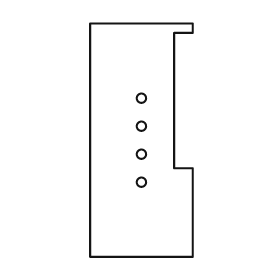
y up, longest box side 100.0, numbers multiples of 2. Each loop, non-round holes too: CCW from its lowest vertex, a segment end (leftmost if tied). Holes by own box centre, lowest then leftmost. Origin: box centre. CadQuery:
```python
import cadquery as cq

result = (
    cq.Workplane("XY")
    .moveTo(-22.0, -50.0)
    .lineTo(22.0, -50.0)
    .lineTo(22.0, -12.0)
    .lineTo(14.0, -12.0)
    .lineTo(14.0, 46.0)
    .lineTo(22.0, 46.0)
    .lineTo(22.0, 50.0)
    .lineTo(-22.0, 50.0)
    .close()
    .moveTo(0.0, -18.0)
    .circle(2.0)
    .moveTo(0.0, -6.0)
    .circle(2.0)
    .moveTo(0.0, 6.0)
    .circle(2.0)
    .moveTo(0.0, 18.0)
    .circle(2.0)
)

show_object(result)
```